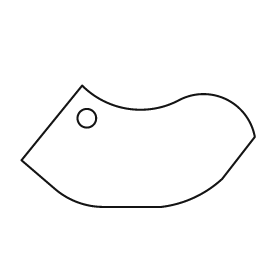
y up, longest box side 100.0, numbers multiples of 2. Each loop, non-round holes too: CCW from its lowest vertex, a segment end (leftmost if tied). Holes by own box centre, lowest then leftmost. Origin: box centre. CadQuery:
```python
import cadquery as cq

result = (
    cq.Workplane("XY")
    .moveTo(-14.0, -26.0)
    .lineTo(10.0, -26.0)
    .threePointArc((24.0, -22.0), (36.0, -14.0))
    .lineTo(50.0, 4.0)
    .threePointArc((38.0, 20.0), (18.0, 20.0))
    .threePointArc((-4.0, 16.0), (-24.0, 26.0))
    .lineTo(-50.0, -6.0)
    .lineTo(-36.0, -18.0)
    .threePointArc((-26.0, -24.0), (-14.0, -26.0))
    .close()
    .moveTo(-22.0, 12.0)
    .circle(4.0)
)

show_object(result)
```